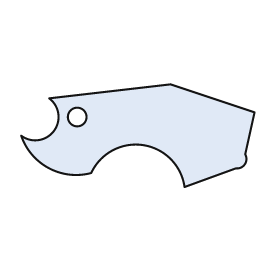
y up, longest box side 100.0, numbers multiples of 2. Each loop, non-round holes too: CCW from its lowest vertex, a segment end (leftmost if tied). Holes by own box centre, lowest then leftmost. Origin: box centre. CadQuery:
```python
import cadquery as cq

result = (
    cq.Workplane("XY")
    .moveTo(20.0, -22.0)
    .lineTo(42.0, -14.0)
    .threePointArc((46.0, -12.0), (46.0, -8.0))
    .lineTo(50.0, 10.0)
    .lineTo(14.0, 22.0)
    .lineTo(-38.0, 16.0)
    .threePointArc((-36.0, 2.0), (-50.0, 0.0))
    .threePointArc((-38.0, -14.0), (-20.0, -16.0))
    .threePointArc((2.0, -4.0), (20.0, -22.0))
    .close()
    .moveTo(-26.0, 8.0)
    .circle(4.0)
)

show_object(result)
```